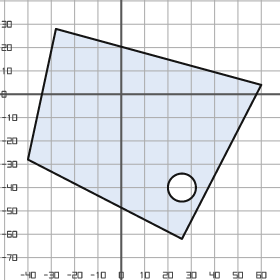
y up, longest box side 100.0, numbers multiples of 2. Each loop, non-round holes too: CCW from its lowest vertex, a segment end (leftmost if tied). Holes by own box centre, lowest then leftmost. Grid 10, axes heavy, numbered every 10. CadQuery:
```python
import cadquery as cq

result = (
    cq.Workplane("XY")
    .moveTo(26.0, -62.0)
    .lineTo(60.0, 4.0)
    .lineTo(-28.0, 28.0)
    .lineTo(-40.0, -28.0)
    .close()
    .moveTo(26.0, -40.0)
    .circle(6.0)
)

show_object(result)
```